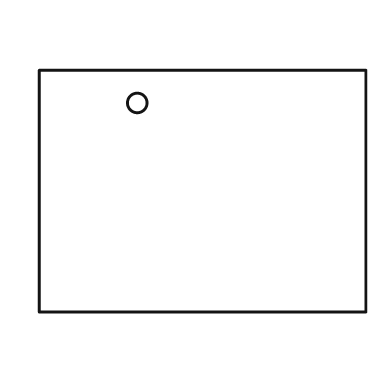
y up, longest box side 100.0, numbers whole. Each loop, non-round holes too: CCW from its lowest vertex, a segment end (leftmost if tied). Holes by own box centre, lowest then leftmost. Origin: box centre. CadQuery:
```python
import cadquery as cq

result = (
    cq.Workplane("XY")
    .moveTo(-50.0, -37.0)
    .lineTo(50.0, -37.0)
    .lineTo(50.0, 37.0)
    .lineTo(-50.0, 37.0)
    .close()
    .moveTo(-20.0, 27.0)
    .circle(3.0)
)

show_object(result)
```